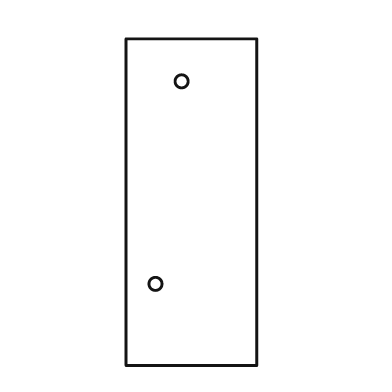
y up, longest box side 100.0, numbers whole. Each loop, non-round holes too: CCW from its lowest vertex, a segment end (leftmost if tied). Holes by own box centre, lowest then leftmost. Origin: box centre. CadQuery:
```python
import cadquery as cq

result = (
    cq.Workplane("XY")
    .moveTo(-20.0, -50.0)
    .lineTo(20.0, -50.0)
    .lineTo(20.0, 50.0)
    .lineTo(-20.0, 50.0)
    .close()
    .moveTo(-11.0, -25.0)
    .circle(2.0)
    .moveTo(-3.0, 37.0)
    .circle(2.0)
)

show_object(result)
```